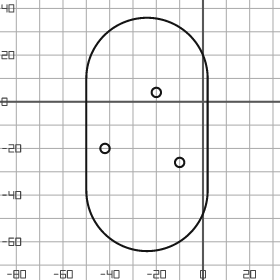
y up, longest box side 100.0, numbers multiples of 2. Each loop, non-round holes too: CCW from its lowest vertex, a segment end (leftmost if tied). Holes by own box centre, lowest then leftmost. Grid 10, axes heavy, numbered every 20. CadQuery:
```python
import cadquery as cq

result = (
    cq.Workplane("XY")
    .moveTo(-50.0, -38.0)
    .threePointArc((-24.0, -64.0), (2.0, -38.0))
    .lineTo(2.0, 10.0)
    .threePointArc((-24.0, 36.0), (-50.0, 10.0))
    .close()
    .moveTo(-10.0, -26.0)
    .circle(2.0)
    .moveTo(-42.0, -20.0)
    .circle(2.0)
    .moveTo(-20.0, 4.0)
    .circle(2.0)
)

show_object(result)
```